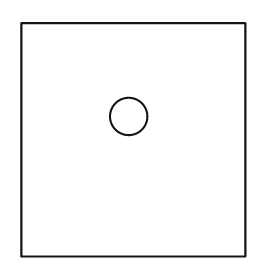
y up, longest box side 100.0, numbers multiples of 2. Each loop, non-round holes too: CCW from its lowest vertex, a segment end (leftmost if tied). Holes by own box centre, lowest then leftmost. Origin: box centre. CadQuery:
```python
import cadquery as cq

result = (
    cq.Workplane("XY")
    .moveTo(-48.0, -50.0)
    .lineTo(48.0, -50.0)
    .lineTo(48.0, 50.0)
    .lineTo(-48.0, 50.0)
    .close()
    .moveTo(-2.0, 10.0)
    .circle(8.0)
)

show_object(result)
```